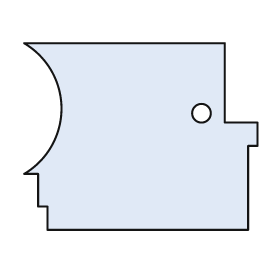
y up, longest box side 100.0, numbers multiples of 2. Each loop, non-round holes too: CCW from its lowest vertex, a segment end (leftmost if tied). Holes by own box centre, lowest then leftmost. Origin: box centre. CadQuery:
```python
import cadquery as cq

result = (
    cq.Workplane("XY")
    .moveTo(-40.0, -40.0)
    .lineTo(46.0, -40.0)
    .lineTo(46.0, -4.0)
    .lineTo(50.0, -4.0)
    .lineTo(50.0, 6.0)
    .lineTo(36.0, 6.0)
    .lineTo(36.0, 40.0)
    .lineTo(-50.0, 40.0)
    .threePointArc((-34.0, 12.0), (-50.0, -16.0))
    .lineTo(-44.0, -16.0)
    .lineTo(-44.0, -30.0)
    .lineTo(-40.0, -30.0)
    .close()
    .moveTo(26.0, 10.0)
    .circle(4.0)
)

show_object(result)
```